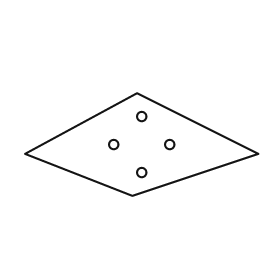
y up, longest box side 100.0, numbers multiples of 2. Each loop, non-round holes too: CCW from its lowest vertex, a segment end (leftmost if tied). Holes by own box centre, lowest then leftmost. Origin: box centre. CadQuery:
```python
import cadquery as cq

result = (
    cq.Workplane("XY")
    .moveTo(-4.0, -22.0)
    .lineTo(50.0, -4.0)
    .lineTo(-2.0, 22.0)
    .lineTo(-50.0, -4.0)
    .close()
    .moveTo(0.0, -12.0)
    .circle(2.0)
    .moveTo(-12.0, 0.0)
    .circle(2.0)
    .moveTo(12.0, 0.0)
    .circle(2.0)
    .moveTo(0.0, 12.0)
    .circle(2.0)
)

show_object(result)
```